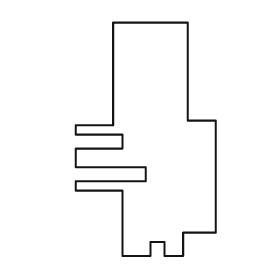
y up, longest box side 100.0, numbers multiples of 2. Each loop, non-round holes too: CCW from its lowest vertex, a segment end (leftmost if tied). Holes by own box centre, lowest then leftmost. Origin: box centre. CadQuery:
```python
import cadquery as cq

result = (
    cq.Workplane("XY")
    .moveTo(-10.0, -50.0)
    .lineTo(2.0, -50.0)
    .lineTo(2.0, -44.0)
    .lineTo(8.0, -44.0)
    .lineTo(8.0, -50.0)
    .lineTo(16.0, -50.0)
    .lineTo(16.0, -40.0)
    .lineTo(30.0, -40.0)
    .lineTo(30.0, 8.0)
    .lineTo(18.0, 8.0)
    .lineTo(18.0, 50.0)
    .lineTo(-14.0, 50.0)
    .lineTo(-14.0, 6.0)
    .lineTo(-30.0, 6.0)
    .lineTo(-30.0, 2.0)
    .lineTo(-10.0, 2.0)
    .lineTo(-10.0, -4.0)
    .lineTo(-30.0, -4.0)
    .lineTo(-30.0, -12.0)
    .lineTo(0.0, -12.0)
    .lineTo(0.0, -18.0)
    .lineTo(-30.0, -18.0)
    .lineTo(-30.0, -22.0)
    .lineTo(-10.0, -22.0)
    .close()
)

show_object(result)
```